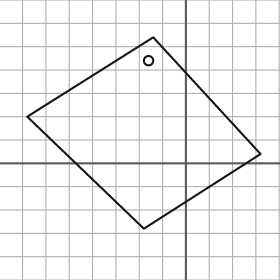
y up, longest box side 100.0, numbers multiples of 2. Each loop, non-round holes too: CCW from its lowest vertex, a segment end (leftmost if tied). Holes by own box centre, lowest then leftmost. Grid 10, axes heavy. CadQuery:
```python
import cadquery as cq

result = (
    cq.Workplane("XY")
    .moveTo(-18.0, -28.0)
    .lineTo(32.0, 4.0)
    .lineTo(-14.0, 54.0)
    .lineTo(-68.0, 20.0)
    .close()
    .moveTo(-16.0, 44.0)
    .circle(2.0)
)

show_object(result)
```